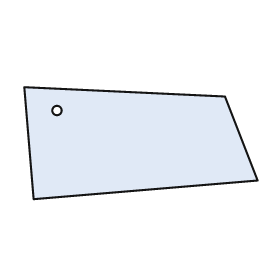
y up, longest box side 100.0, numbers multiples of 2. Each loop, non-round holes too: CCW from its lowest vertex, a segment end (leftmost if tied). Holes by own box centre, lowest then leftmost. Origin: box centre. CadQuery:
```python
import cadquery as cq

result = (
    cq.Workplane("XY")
    .moveTo(-46.0, -24.0)
    .lineTo(50.0, -16.0)
    .lineTo(36.0, 20.0)
    .lineTo(-50.0, 24.0)
    .close()
    .moveTo(-36.0, 14.0)
    .circle(2.0)
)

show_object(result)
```